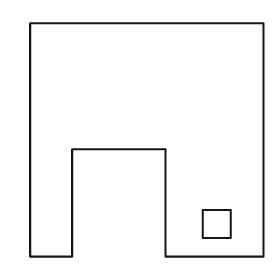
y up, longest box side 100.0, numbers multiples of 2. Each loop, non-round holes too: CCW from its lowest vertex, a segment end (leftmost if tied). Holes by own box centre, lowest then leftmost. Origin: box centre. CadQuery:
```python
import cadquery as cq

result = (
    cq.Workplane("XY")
    .moveTo(-50.0, -50.0)
    .lineTo(-32.0, -50.0)
    .lineTo(-32.0, -4.0)
    .lineTo(8.0, -4.0)
    .lineTo(8.0, -50.0)
    .lineTo(50.0, -50.0)
    .lineTo(50.0, 50.0)
    .lineTo(-50.0, 50.0)
    .close()
    .moveTo(24.0, -42.0)
    .lineTo(36.0, -42.0)
    .lineTo(36.0, -30.0)
    .lineTo(24.0, -30.0)
    .close()
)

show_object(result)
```